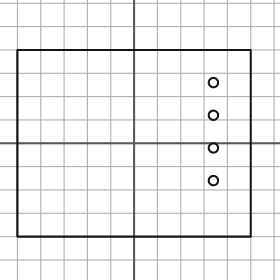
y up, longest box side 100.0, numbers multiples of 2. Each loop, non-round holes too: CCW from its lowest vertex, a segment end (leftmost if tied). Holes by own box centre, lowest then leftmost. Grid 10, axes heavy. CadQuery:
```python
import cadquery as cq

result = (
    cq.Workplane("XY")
    .moveTo(-50.0, -40.0)
    .lineTo(50.0, -40.0)
    .lineTo(50.0, 40.0)
    .lineTo(-50.0, 40.0)
    .close()
    .moveTo(34.0, -16.0)
    .circle(2.0)
    .moveTo(34.0, -2.0)
    .circle(2.0)
    .moveTo(34.0, 12.0)
    .circle(2.0)
    .moveTo(34.0, 26.0)
    .circle(2.0)
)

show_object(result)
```